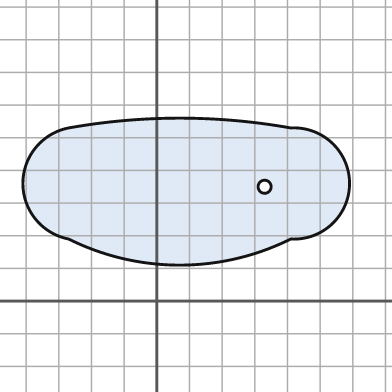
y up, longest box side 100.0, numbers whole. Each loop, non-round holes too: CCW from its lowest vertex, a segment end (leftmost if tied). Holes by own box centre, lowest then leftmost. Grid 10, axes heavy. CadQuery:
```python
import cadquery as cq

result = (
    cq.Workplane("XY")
    .moveTo(-27.0, 19.0)
    .threePointArc((7.0, 11.0), (41.0, 19.0))
    .threePointArc((59.0, 36.0), (41.0, 53.0))
    .threePointArc((7.0, 56.0), (-27.0, 53.0))
    .threePointArc((-41.0, 36.0), (-27.0, 19.0))
    .close()
    .moveTo(33.0, 35.0)
    .circle(2.0)
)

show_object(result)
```